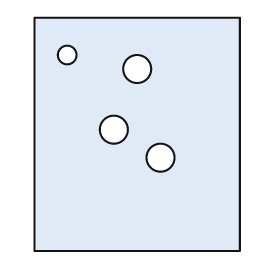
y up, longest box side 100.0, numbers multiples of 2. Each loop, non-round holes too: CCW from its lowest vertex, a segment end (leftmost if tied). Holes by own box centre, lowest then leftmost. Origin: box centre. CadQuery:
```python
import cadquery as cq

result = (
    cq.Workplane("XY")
    .moveTo(-44.0, -50.0)
    .lineTo(44.0, -50.0)
    .lineTo(44.0, 50.0)
    .lineTo(-44.0, 50.0)
    .close()
    .moveTo(10.0, -10.0)
    .circle(6.0)
    .moveTo(-10.0, 2.0)
    .circle(6.0)
    .moveTo(0.0, 28.0)
    .circle(6.0)
    .moveTo(-30.0, 34.0)
    .circle(4.0)
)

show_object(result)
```